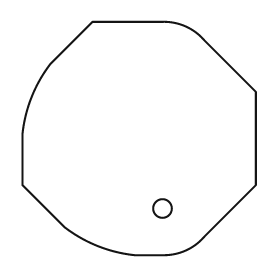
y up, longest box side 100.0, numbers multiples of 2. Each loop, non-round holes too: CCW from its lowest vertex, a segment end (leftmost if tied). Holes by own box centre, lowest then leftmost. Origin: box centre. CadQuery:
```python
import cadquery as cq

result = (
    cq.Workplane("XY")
    .moveTo(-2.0, -50.0)
    .lineTo(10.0, -50.0)
    .threePointArc((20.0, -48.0), (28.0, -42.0))
    .lineTo(50.0, -20.0)
    .lineTo(50.0, 20.0)
    .lineTo(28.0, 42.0)
    .threePointArc((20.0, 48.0), (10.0, 50.0))
    .lineTo(-20.0, 50.0)
    .lineTo(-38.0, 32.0)
    .threePointArc((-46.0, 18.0), (-50.0, 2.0))
    .lineTo(-50.0, -20.0)
    .lineTo(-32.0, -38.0)
    .threePointArc((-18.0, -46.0), (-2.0, -50.0))
    .close()
    .moveTo(10.0, -30.0)
    .circle(4.0)
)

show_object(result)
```